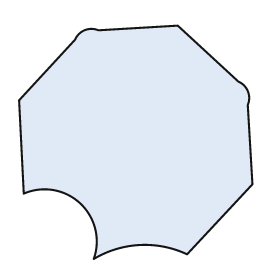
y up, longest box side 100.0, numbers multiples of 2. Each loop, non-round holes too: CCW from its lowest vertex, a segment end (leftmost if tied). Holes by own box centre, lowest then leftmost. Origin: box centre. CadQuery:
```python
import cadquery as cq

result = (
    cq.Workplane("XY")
    .moveTo(-18.0, -50.0)
    .threePointArc((2.0, -44.0), (22.0, -48.0))
    .lineTo(50.0, -18.0)
    .lineTo(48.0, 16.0)
    .threePointArc((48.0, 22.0), (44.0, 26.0))
    .lineTo(18.0, 50.0)
    .lineTo(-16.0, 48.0)
    .threePointArc((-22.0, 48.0), (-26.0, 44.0))
    .lineTo(-50.0, 18.0)
    .lineTo(-48.0, -22.0)
    .threePointArc((-24.0, -26.0), (-18.0, -50.0))
    .close()
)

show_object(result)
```